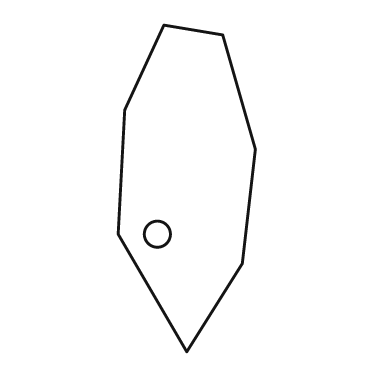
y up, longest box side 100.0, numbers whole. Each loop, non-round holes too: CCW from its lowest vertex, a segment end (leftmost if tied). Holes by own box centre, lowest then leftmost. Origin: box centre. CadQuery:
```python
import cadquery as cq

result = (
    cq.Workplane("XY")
    .moveTo(0.0, -50.0)
    .lineTo(17.0, -23.0)
    .lineTo(21.0, 12.0)
    .lineTo(11.0, 47.0)
    .lineTo(-7.0, 50.0)
    .lineTo(-19.0, 24.0)
    .lineTo(-21.0, -14.0)
    .close()
    .moveTo(-9.0, -14.0)
    .circle(4.0)
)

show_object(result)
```